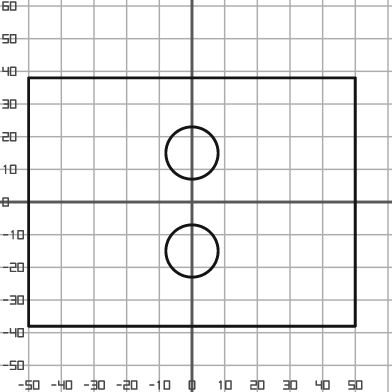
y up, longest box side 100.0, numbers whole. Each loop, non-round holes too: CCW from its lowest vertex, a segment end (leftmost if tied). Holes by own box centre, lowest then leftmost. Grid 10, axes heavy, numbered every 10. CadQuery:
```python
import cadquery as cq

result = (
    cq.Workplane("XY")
    .moveTo(-50.0, -38.0)
    .lineTo(50.0, -38.0)
    .lineTo(50.0, 38.0)
    .lineTo(-50.0, 38.0)
    .close()
    .moveTo(0.0, -15.0)
    .circle(8.0)
    .moveTo(0.0, 15.0)
    .circle(8.0)
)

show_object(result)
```